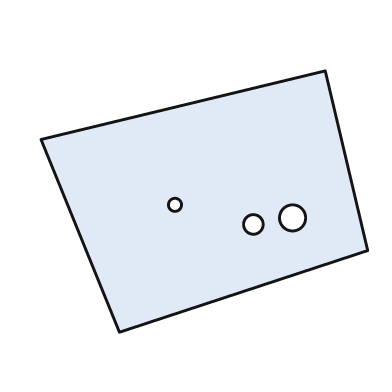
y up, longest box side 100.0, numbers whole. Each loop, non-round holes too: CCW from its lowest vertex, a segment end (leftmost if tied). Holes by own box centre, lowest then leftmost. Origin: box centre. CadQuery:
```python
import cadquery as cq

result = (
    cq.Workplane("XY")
    .moveTo(-26.0, -40.0)
    .lineTo(50.0, -15.0)
    .lineTo(37.0, 40.0)
    .lineTo(-50.0, 19.0)
    .close()
    .moveTo(15.0, -7.0)
    .circle(3.0)
    .moveTo(27.0, -5.0)
    .circle(4.0)
    .moveTo(-9.0, -1.0)
    .circle(2.0)
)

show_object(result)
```